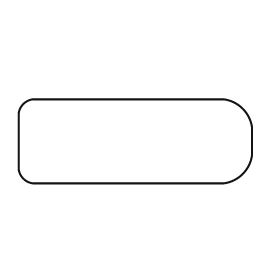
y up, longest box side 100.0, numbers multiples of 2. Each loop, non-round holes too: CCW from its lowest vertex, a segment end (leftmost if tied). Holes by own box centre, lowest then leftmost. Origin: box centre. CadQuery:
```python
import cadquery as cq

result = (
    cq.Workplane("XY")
    .moveTo(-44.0, -18.0)
    .lineTo(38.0, -18.0)
    .threePointArc((46.0, -14.0), (50.0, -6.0))
    .lineTo(50.0, 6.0)
    .threePointArc((46.0, 14.0), (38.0, 18.0))
    .lineTo(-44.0, 18.0)
    .threePointArc((-48.0, 16.0), (-50.0, 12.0))
    .lineTo(-50.0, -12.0)
    .threePointArc((-48.0, -16.0), (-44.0, -18.0))
    .close()
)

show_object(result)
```